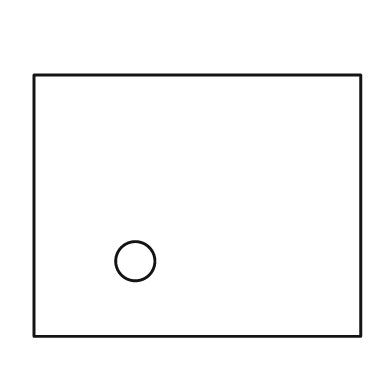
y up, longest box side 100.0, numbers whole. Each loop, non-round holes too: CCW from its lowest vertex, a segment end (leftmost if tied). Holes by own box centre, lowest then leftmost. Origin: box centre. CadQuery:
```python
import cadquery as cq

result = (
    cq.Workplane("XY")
    .moveTo(-50.0, -40.0)
    .lineTo(50.0, -40.0)
    .lineTo(50.0, 40.0)
    .lineTo(-50.0, 40.0)
    .close()
    .moveTo(-19.0, -17.0)
    .circle(6.0)
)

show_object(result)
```